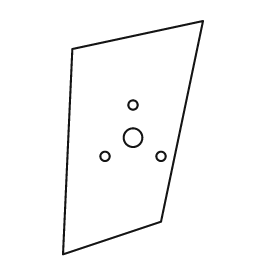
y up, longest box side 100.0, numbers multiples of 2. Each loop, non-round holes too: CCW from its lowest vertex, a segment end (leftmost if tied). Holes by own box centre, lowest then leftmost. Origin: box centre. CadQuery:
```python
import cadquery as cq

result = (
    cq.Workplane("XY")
    .moveTo(-30.0, -50.0)
    .lineTo(12.0, -36.0)
    .lineTo(30.0, 50.0)
    .lineTo(-26.0, 38.0)
    .close()
    .moveTo(-12.0, -8.0)
    .circle(2.0)
    .moveTo(12.0, -8.0)
    .circle(2.0)
    .moveTo(0.0, 0.0)
    .circle(4.0)
    .moveTo(0.0, 14.0)
    .circle(2.0)
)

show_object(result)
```